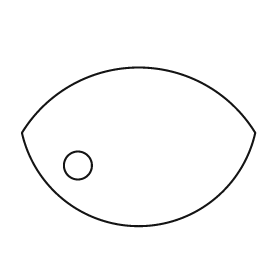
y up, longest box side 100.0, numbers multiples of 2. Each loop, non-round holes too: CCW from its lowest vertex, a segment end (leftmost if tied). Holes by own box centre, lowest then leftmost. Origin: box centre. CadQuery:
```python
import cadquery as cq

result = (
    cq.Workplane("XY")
    .moveTo(-50.0, 6.0)
    .threePointArc((0.0, -34.0), (50.0, 6.0))
    .threePointArc((0.0, 34.0), (-50.0, 6.0))
    .close()
    .moveTo(-26.0, -8.0)
    .circle(6.0)
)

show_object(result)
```